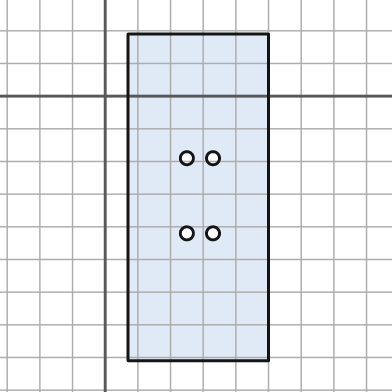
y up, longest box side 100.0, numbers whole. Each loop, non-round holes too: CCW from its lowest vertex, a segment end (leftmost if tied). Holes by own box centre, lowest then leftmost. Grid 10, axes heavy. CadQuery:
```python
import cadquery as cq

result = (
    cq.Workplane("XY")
    .moveTo(7.0, -81.0)
    .lineTo(50.0, -81.0)
    .lineTo(50.0, 19.0)
    .lineTo(7.0, 19.0)
    .close()
    .moveTo(25.0, -42.0)
    .circle(2.0)
    .moveTo(33.0, -42.0)
    .circle(2.0)
    .moveTo(25.0, -19.0)
    .circle(2.0)
    .moveTo(33.0, -19.0)
    .circle(2.0)
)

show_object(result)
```